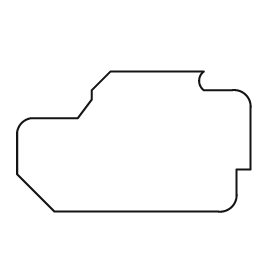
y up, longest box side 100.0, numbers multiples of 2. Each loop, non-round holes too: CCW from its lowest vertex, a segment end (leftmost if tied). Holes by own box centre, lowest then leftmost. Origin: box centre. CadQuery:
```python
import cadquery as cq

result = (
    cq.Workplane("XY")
    .moveTo(-34.0, -30.0)
    .lineTo(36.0, -30.0)
    .threePointArc((42.0, -28.0), (44.0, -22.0))
    .lineTo(44.0, -12.0)
    .lineTo(50.0, -12.0)
    .lineTo(50.0, 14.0)
    .threePointArc((48.0, 20.0), (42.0, 22.0))
    .lineTo(30.0, 22.0)
    .threePointArc((28.0, 26.0), (30.0, 30.0))
    .lineTo(-10.0, 30.0)
    .lineTo(-18.0, 22.0)
    .lineTo(-18.0, 18.0)
    .lineTo(-24.0, 10.0)
    .lineTo(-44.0, 10.0)
    .threePointArc((-48.0, 8.0), (-50.0, 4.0))
    .lineTo(-50.0, -14.0)
    .close()
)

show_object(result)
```